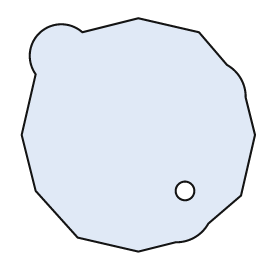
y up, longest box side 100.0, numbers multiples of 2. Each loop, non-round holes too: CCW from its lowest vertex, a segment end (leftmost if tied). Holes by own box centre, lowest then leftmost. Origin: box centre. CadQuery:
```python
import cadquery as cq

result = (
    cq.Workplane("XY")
    .moveTo(0.0, -50.0)
    .lineTo(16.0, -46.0)
    .threePointArc((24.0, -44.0), (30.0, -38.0))
    .lineTo(44.0, -26.0)
    .lineTo(50.0, 0.0)
    .lineTo(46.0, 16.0)
    .threePointArc((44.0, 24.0), (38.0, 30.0))
    .lineTo(26.0, 44.0)
    .lineTo(0.0, 50.0)
    .lineTo(-24.0, 44.0)
    .threePointArc((-42.0, 44.0), (-44.0, 26.0))
    .lineTo(-50.0, 0.0)
    .lineTo(-44.0, -24.0)
    .lineTo(-26.0, -44.0)
    .close()
    .moveTo(20.0, -24.0)
    .circle(4.0)
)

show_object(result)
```